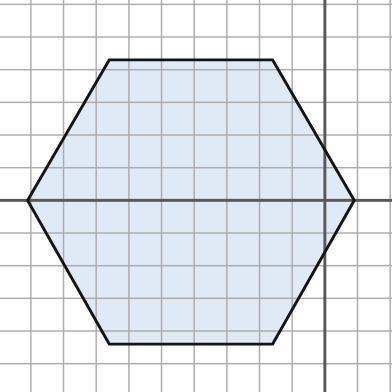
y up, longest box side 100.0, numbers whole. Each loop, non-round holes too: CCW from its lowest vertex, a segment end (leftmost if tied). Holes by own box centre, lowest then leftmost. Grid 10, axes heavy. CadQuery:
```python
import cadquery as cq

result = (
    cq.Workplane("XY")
    .moveTo(-66.0, -44.0)
    .lineTo(-16.0, -44.0)
    .lineTo(9.0, 0.0)
    .lineTo(-16.0, 43.0)
    .lineTo(-66.0, 43.0)
    .lineTo(-91.0, 0.0)
    .close()
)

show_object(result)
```